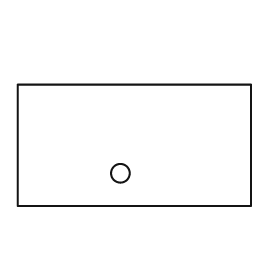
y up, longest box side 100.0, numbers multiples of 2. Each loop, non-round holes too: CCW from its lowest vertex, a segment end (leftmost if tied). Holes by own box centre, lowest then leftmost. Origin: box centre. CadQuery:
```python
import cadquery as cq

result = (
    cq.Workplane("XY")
    .moveTo(-50.0, -26.0)
    .lineTo(50.0, -26.0)
    .lineTo(50.0, 26.0)
    .lineTo(-50.0, 26.0)
    .close()
    .moveTo(-6.0, -12.0)
    .circle(4.0)
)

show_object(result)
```